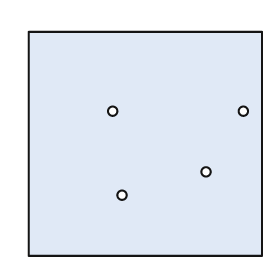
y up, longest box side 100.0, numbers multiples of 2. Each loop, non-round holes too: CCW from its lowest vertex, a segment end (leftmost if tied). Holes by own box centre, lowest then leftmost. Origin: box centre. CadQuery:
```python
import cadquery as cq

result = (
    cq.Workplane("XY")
    .moveTo(-50.0, -48.0)
    .lineTo(50.0, -48.0)
    .lineTo(50.0, 48.0)
    .lineTo(-50.0, 48.0)
    .close()
    .moveTo(-10.0, -22.0)
    .circle(2.0)
    .moveTo(26.0, -12.0)
    .circle(2.0)
    .moveTo(-14.0, 14.0)
    .circle(2.0)
    .moveTo(42.0, 14.0)
    .circle(2.0)
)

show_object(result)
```